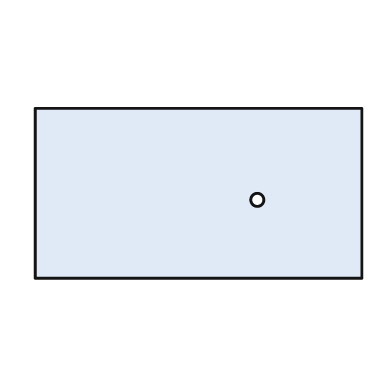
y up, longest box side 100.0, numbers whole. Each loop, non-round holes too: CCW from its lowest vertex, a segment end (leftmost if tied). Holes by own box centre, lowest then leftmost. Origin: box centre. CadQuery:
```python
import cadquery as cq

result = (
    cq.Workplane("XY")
    .moveTo(-50.0, -26.0)
    .lineTo(50.0, -26.0)
    .lineTo(50.0, 26.0)
    .lineTo(-50.0, 26.0)
    .close()
    .moveTo(18.0, -2.0)
    .circle(2.0)
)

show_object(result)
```